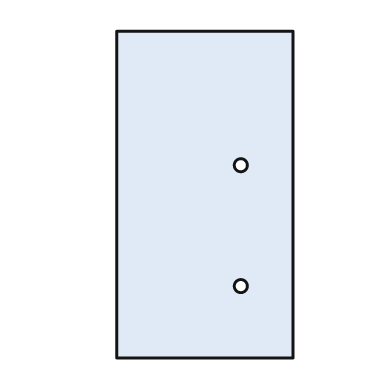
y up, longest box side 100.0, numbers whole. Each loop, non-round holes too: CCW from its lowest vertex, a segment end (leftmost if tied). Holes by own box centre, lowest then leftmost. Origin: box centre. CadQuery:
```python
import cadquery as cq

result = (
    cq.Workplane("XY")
    .moveTo(-27.0, -50.0)
    .lineTo(27.0, -50.0)
    .lineTo(27.0, 50.0)
    .lineTo(-27.0, 50.0)
    .close()
    .moveTo(11.0, -28.0)
    .circle(2.0)
    .moveTo(11.0, 9.0)
    .circle(2.0)
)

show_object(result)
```